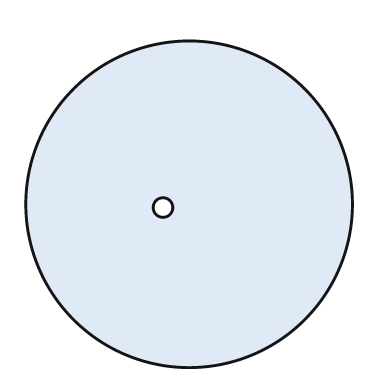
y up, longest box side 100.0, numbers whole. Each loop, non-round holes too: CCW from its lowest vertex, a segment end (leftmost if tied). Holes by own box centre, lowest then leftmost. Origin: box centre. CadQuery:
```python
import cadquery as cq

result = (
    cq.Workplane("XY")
    .moveTo(0.0, 0.0)
    .circle(50.0)
    .moveTo(-8.0, -1.0)
    .circle(3.0)
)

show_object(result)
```